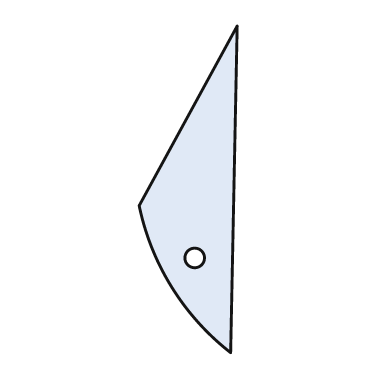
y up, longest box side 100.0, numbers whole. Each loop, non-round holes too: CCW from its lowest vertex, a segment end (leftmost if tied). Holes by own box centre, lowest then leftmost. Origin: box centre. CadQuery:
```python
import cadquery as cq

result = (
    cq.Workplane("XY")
    .moveTo(13.0, -50.0)
    .lineTo(15.0, 50.0)
    .lineTo(-15.0, -5.0)
    .threePointArc((-5.0, -30.0), (13.0, -50.0))
    .close()
    .moveTo(2.0, -21.0)
    .circle(3.0)
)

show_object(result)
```